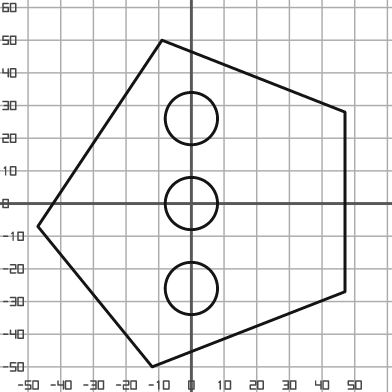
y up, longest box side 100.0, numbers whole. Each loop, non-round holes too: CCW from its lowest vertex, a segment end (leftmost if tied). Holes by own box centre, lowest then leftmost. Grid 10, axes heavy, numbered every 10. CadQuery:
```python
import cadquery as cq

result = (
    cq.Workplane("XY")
    .moveTo(-12.0, -50.0)
    .lineTo(47.0, -27.0)
    .lineTo(47.0, 28.0)
    .lineTo(-9.0, 50.0)
    .lineTo(-47.0, -7.0)
    .close()
    .moveTo(0.0, -26.0)
    .circle(8.0)
    .moveTo(0.0, 0.0)
    .circle(8.0)
    .moveTo(0.0, 26.0)
    .circle(8.0)
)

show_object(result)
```